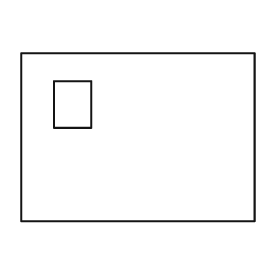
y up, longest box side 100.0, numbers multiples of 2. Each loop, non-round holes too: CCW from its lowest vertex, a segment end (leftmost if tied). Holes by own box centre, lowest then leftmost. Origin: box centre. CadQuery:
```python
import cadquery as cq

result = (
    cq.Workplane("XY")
    .moveTo(-50.0, -36.0)
    .lineTo(50.0, -36.0)
    .lineTo(50.0, 36.0)
    .lineTo(-50.0, 36.0)
    .close()
    .moveTo(-36.0, 4.0)
    .lineTo(-20.0, 4.0)
    .lineTo(-20.0, 24.0)
    .lineTo(-36.0, 24.0)
    .close()
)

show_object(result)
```